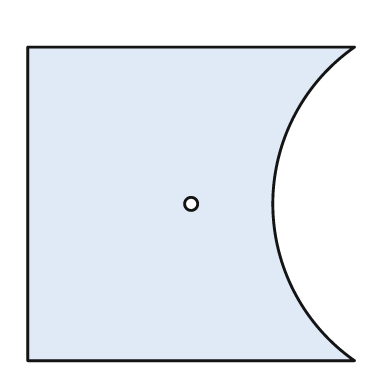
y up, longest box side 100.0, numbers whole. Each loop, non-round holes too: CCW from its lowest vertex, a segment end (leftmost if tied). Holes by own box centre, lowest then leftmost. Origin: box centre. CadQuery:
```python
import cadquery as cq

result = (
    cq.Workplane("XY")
    .moveTo(-50.0, -48.0)
    .lineTo(50.0, -48.0)
    .threePointArc((25.0, 0.0), (50.0, 48.0))
    .lineTo(-50.0, 48.0)
    .close()
    .moveTo(0.0, 0.0)
    .circle(2.0)
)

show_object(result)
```